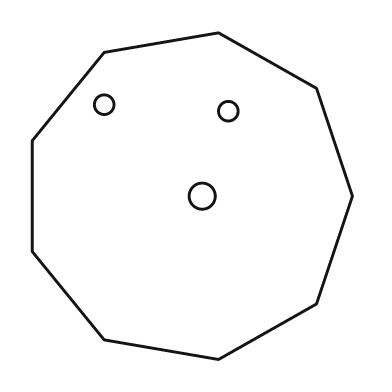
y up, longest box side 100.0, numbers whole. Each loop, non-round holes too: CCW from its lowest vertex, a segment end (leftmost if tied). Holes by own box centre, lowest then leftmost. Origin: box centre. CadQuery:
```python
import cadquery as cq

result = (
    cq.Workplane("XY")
    .moveTo(8.0, -50.0)
    .lineTo(38.0, -33.0)
    .lineTo(49.0, 0.0)
    .lineTo(38.0, 33.0)
    .lineTo(8.0, 50.0)
    .lineTo(-27.0, 44.0)
    .lineTo(-49.0, 17.0)
    .lineTo(-49.0, -17.0)
    .lineTo(-27.0, -44.0)
    .close()
    .moveTo(3.0, 0.0)
    .circle(4.0)
    .moveTo(11.0, 26.0)
    .circle(3.0)
    .moveTo(-27.0, 28.0)
    .circle(3.0)
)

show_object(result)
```